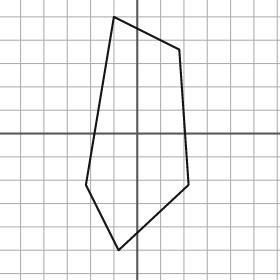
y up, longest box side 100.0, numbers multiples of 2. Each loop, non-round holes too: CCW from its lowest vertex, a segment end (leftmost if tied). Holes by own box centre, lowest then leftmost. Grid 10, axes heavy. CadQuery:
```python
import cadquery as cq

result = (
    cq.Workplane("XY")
    .moveTo(-8.0, -50.0)
    .lineTo(22.0, -22.0)
    .lineTo(18.0, 36.0)
    .lineTo(-10.0, 50.0)
    .lineTo(-22.0, -22.0)
    .close()
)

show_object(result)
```